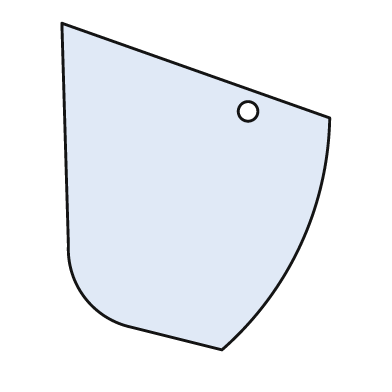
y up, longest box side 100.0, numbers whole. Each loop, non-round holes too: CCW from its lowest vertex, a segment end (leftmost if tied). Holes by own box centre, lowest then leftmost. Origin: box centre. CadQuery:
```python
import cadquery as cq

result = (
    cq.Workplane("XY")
    .moveTo(8.0, -50.0)
    .threePointArc((32.0, -18.0), (41.0, 21.0))
    .lineTo(-41.0, 50.0)
    .lineTo(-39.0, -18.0)
    .threePointArc((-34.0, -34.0), (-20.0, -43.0))
    .close()
    .moveTo(16.0, 23.0)
    .circle(3.0)
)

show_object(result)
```